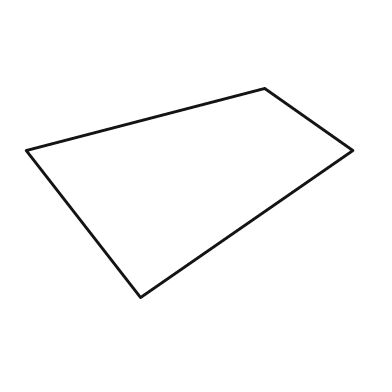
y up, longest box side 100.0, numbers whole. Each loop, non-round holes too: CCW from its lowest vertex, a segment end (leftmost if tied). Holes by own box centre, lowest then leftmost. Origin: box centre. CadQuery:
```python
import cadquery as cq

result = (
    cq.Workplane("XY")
    .moveTo(-15.0, -32.0)
    .lineTo(50.0, 13.0)
    .lineTo(23.0, 32.0)
    .lineTo(-50.0, 13.0)
    .close()
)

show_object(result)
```